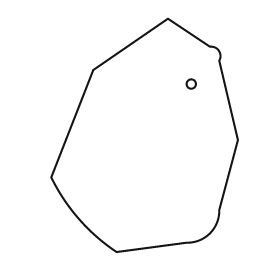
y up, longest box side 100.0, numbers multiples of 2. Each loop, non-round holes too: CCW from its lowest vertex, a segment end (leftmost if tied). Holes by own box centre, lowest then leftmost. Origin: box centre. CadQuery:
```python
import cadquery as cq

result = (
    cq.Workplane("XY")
    .moveTo(-12.0, -50.0)
    .lineTo(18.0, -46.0)
    .threePointArc((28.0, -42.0), (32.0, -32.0))
    .lineTo(40.0, -2.0)
    .lineTo(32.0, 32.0)
    .threePointArc((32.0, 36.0), (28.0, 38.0))
    .lineTo(10.0, 50.0)
    .lineTo(-22.0, 28.0)
    .lineTo(-40.0, -18.0)
    .threePointArc((-28.0, -36.0), (-12.0, -50.0))
    .close()
    .moveTo(20.0, 22.0)
    .circle(2.0)
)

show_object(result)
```